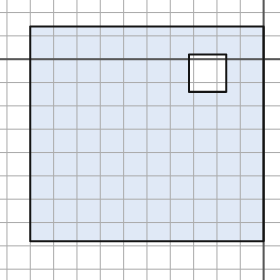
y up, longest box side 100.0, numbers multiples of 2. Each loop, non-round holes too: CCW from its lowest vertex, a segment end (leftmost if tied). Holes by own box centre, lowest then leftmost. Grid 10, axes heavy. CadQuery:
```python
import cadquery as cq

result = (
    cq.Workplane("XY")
    .moveTo(-100.0, -78.0)
    .lineTo(0.0, -78.0)
    .lineTo(0.0, 14.0)
    .lineTo(-100.0, 14.0)
    .close()
    .moveTo(-32.0, -14.0)
    .lineTo(-16.0, -14.0)
    .lineTo(-16.0, 2.0)
    .lineTo(-32.0, 2.0)
    .close()
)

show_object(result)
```